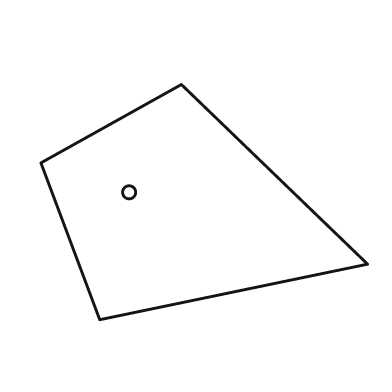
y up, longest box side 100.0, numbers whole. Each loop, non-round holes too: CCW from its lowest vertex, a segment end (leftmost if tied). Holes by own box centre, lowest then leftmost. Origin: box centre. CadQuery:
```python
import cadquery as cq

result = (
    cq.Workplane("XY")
    .moveTo(-32.0, -36.0)
    .lineTo(50.0, -19.0)
    .lineTo(-7.0, 36.0)
    .lineTo(-50.0, 12.0)
    .close()
    .moveTo(-23.0, 3.0)
    .circle(2.0)
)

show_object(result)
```